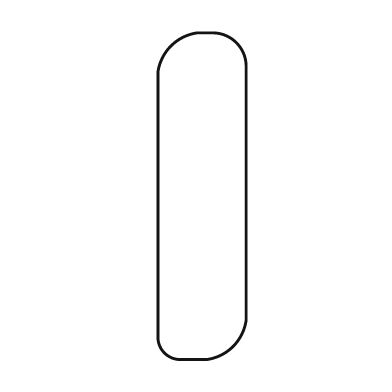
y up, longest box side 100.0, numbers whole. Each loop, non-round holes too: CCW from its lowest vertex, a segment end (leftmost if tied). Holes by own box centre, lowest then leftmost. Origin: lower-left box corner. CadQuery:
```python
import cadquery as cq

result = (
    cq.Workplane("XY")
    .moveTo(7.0, 0.0)
    .lineTo(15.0, 0.0)
    .threePointArc((23.0, 4.0), (27.0, 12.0))
    .lineTo(27.0, 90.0)
    .threePointArc((24.0, 97.0), (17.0, 100.0))
    .lineTo(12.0, 100.0)
    .threePointArc((4.0, 96.0), (0.0, 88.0))
    .lineTo(0.0, 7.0)
    .threePointArc((2.0, 2.0), (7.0, 0.0))
    .close()
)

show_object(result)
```